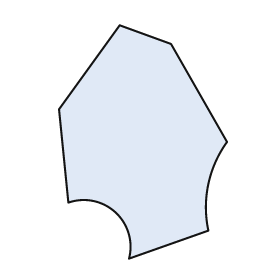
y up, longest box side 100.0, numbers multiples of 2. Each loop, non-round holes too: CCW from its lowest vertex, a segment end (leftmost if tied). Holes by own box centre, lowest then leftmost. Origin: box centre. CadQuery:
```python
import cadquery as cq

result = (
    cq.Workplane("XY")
    .moveTo(-6.0, -50.0)
    .lineTo(28.0, -38.0)
    .threePointArc((28.0, -18.0), (36.0, 0.0))
    .lineTo(12.0, 42.0)
    .lineTo(-10.0, 50.0)
    .lineTo(-36.0, 14.0)
    .lineTo(-32.0, -26.0)
    .threePointArc((-12.0, -30.0), (-6.0, -50.0))
    .close()
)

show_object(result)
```